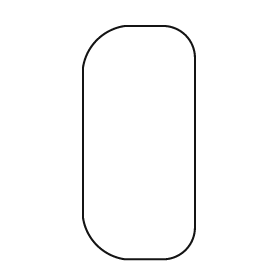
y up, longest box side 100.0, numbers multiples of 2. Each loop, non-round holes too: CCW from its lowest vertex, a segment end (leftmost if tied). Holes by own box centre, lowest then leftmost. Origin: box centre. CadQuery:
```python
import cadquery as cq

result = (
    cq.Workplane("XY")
    .moveTo(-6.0, -50.0)
    .lineTo(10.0, -50.0)
    .threePointArc((20.0, -46.0), (24.0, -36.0))
    .lineTo(24.0, 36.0)
    .threePointArc((20.0, 46.0), (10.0, 50.0))
    .lineTo(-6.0, 50.0)
    .threePointArc((-18.0, 44.0), (-24.0, 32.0))
    .lineTo(-24.0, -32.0)
    .threePointArc((-18.0, -44.0), (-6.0, -50.0))
    .close()
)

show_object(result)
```